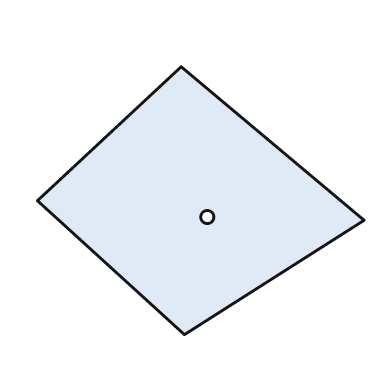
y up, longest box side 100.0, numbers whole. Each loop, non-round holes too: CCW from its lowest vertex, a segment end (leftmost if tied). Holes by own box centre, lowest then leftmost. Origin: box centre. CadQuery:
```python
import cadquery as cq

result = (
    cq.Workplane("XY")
    .moveTo(-5.0, -41.0)
    .lineTo(50.0, -6.0)
    .lineTo(-6.0, 41.0)
    .lineTo(-50.0, 0.0)
    .close()
    .moveTo(2.0, -5.0)
    .circle(2.0)
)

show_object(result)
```